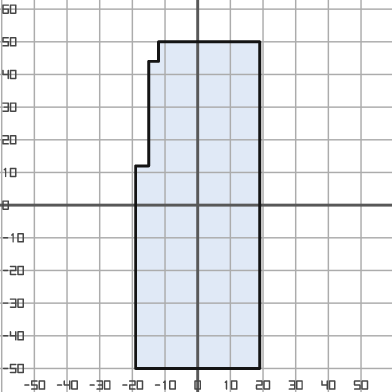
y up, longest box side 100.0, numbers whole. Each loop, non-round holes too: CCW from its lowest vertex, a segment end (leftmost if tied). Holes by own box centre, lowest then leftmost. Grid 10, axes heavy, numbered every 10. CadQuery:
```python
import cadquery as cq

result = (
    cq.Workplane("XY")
    .moveTo(-19.0, -50.0)
    .lineTo(19.0, -50.0)
    .lineTo(19.0, 50.0)
    .lineTo(-12.0, 50.0)
    .lineTo(-12.0, 44.0)
    .lineTo(-15.0, 44.0)
    .lineTo(-15.0, 12.0)
    .lineTo(-19.0, 12.0)
    .close()
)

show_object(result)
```